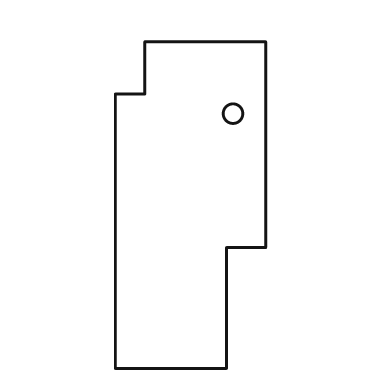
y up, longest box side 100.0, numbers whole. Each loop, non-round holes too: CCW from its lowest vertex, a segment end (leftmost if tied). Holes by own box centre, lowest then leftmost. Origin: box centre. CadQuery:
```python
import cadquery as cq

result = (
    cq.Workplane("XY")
    .moveTo(-23.0, -50.0)
    .lineTo(11.0, -50.0)
    .lineTo(11.0, -13.0)
    .lineTo(23.0, -13.0)
    .lineTo(23.0, 50.0)
    .lineTo(-14.0, 50.0)
    .lineTo(-14.0, 34.0)
    .lineTo(-23.0, 34.0)
    .close()
    .moveTo(13.0, 28.0)
    .circle(3.0)
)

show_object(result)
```